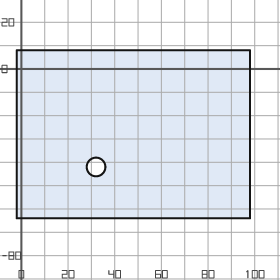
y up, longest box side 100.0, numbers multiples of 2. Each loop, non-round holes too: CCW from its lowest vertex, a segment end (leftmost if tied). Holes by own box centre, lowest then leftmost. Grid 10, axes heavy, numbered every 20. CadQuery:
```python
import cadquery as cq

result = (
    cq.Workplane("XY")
    .moveTo(-2.0, -64.0)
    .lineTo(98.0, -64.0)
    .lineTo(98.0, 8.0)
    .lineTo(-2.0, 8.0)
    .close()
    .moveTo(32.0, -42.0)
    .circle(4.0)
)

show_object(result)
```